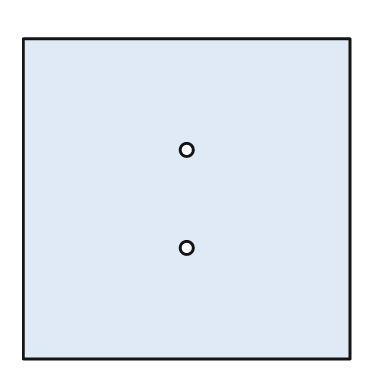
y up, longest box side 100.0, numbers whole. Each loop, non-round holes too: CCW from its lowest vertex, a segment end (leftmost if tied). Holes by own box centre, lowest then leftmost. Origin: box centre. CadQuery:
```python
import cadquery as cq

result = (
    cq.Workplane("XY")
    .moveTo(-50.0, -49.0)
    .lineTo(50.0, -49.0)
    .lineTo(50.0, 49.0)
    .lineTo(-50.0, 49.0)
    .close()
    .moveTo(0.0, -15.0)
    .circle(2.0)
    .moveTo(0.0, 15.0)
    .circle(2.0)
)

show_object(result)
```